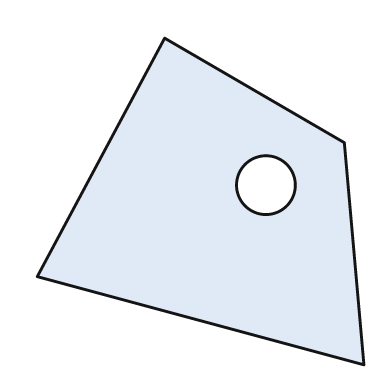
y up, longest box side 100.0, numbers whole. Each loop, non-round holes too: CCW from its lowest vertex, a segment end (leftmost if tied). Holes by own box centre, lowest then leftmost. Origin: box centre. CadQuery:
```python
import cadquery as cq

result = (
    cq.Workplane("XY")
    .moveTo(50.0, -50.0)
    .lineTo(44.0, 18.0)
    .lineTo(-11.0, 50.0)
    .lineTo(-50.0, -23.0)
    .close()
    .moveTo(20.0, 5.0)
    .circle(9.0)
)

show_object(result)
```